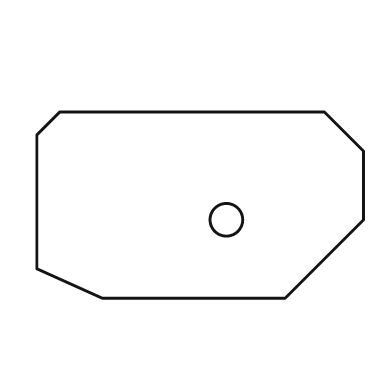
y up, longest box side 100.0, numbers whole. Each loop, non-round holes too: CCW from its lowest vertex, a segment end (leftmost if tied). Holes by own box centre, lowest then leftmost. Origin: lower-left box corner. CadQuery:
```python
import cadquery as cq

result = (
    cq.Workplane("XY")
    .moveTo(20.0, 0.0)
    .lineTo(76.0, 0.0)
    .lineTo(100.0, 24.0)
    .lineTo(100.0, 45.0)
    .lineTo(88.0, 57.0)
    .lineTo(7.0, 57.0)
    .lineTo(0.0, 50.0)
    .lineTo(0.0, 9.0)
    .close()
    .moveTo(58.0, 24.0)
    .circle(5.0)
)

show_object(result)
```